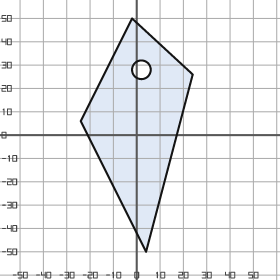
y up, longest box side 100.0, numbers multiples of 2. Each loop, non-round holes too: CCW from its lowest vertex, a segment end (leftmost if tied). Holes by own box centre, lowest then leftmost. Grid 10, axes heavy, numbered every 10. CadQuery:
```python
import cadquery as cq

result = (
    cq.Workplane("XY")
    .moveTo(4.0, -50.0)
    .lineTo(24.0, 26.0)
    .lineTo(-2.0, 50.0)
    .lineTo(-24.0, 6.0)
    .close()
    .moveTo(2.0, 28.0)
    .circle(4.0)
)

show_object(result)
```